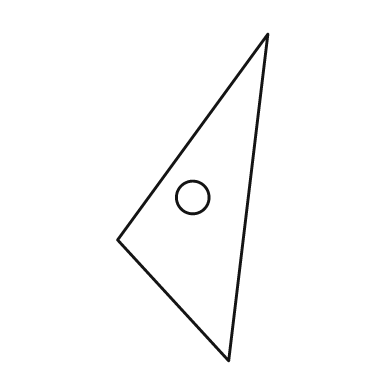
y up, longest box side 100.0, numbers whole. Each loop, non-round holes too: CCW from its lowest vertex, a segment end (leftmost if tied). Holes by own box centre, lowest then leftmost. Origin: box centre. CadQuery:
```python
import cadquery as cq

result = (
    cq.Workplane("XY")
    .moveTo(11.0, -50.0)
    .lineTo(23.0, 50.0)
    .lineTo(-23.0, -13.0)
    .close()
    .moveTo(0.0, 0.0)
    .circle(5.0)
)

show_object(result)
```